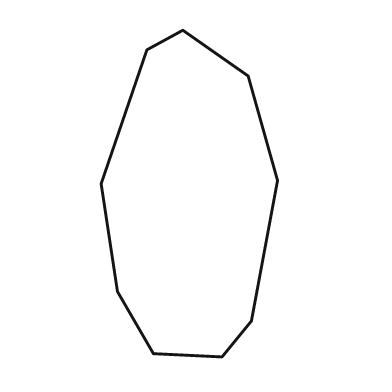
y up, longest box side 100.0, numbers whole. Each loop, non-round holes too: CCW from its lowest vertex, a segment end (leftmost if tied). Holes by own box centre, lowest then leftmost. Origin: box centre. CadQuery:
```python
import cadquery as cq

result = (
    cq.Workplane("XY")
    .moveTo(10.0, -50.0)
    .lineTo(19.0, -39.0)
    .lineTo(27.0, 4.0)
    .lineTo(18.0, 36.0)
    .lineTo(-2.0, 50.0)
    .lineTo(-13.0, 44.0)
    .lineTo(-27.0, 3.0)
    .lineTo(-22.0, -30.0)
    .lineTo(-11.0, -49.0)
    .close()
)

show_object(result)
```